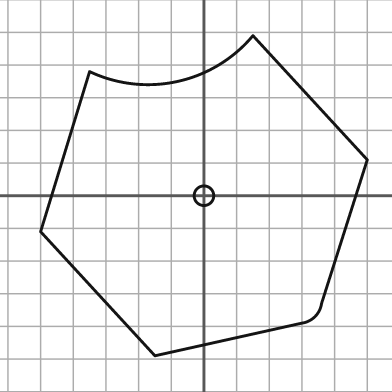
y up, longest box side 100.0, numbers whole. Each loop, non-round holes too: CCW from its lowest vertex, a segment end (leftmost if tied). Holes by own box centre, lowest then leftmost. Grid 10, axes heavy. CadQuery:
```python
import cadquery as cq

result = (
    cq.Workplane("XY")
    .moveTo(-15.0, -49.0)
    .lineTo(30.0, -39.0)
    .threePointArc((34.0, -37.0), (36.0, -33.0))
    .lineTo(50.0, 11.0)
    .lineTo(15.0, 49.0)
    .threePointArc((-8.0, 35.0), (-35.0, 38.0))
    .lineTo(-50.0, -11.0)
    .close()
    .moveTo(0.0, 0.0)
    .circle(3.0)
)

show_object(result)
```